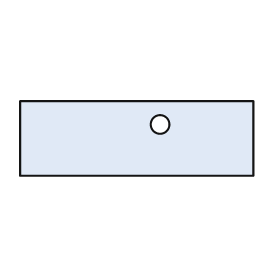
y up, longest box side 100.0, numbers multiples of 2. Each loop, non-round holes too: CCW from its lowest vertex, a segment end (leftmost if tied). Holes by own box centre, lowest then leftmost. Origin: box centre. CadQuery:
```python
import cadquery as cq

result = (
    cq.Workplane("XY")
    .moveTo(-50.0, -16.0)
    .lineTo(50.0, -16.0)
    .lineTo(50.0, 16.0)
    .lineTo(-50.0, 16.0)
    .close()
    .moveTo(10.0, 6.0)
    .circle(4.0)
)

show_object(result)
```